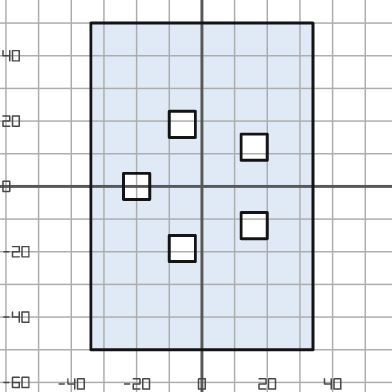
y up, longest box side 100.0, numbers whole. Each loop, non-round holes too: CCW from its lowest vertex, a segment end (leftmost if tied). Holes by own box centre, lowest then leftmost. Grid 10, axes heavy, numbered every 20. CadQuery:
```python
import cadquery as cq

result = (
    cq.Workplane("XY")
    .moveTo(-34.0, -50.0)
    .lineTo(34.0, -50.0)
    .lineTo(34.0, 50.0)
    .lineTo(-34.0, 50.0)
    .close()
    .moveTo(-10.0, -23.0)
    .lineTo(-2.0, -23.0)
    .lineTo(-2.0, -15.0)
    .lineTo(-10.0, -15.0)
    .close()
    .moveTo(12.0, -16.0)
    .lineTo(20.0, -16.0)
    .lineTo(20.0, -8.0)
    .lineTo(12.0, -8.0)
    .close()
    .moveTo(-24.0, -4.0)
    .lineTo(-16.0, -4.0)
    .lineTo(-16.0, 4.0)
    .lineTo(-24.0, 4.0)
    .close()
    .moveTo(12.0, 8.0)
    .lineTo(20.0, 8.0)
    .lineTo(20.0, 16.0)
    .lineTo(12.0, 16.0)
    .close()
    .moveTo(-10.0, 15.0)
    .lineTo(-2.0, 15.0)
    .lineTo(-2.0, 23.0)
    .lineTo(-10.0, 23.0)
    .close()
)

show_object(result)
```